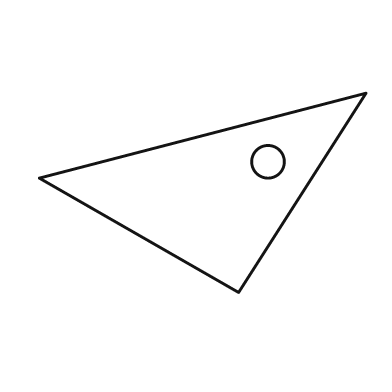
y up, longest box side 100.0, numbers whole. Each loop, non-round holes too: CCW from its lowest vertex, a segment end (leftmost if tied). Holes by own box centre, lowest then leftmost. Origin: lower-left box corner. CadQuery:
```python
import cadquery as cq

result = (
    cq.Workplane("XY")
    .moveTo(61.0, 0.0)
    .lineTo(100.0, 61.0)
    .lineTo(0.0, 35.0)
    .close()
    .moveTo(70.0, 40.0)
    .circle(5.0)
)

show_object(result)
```